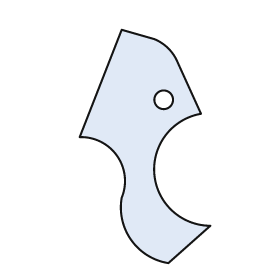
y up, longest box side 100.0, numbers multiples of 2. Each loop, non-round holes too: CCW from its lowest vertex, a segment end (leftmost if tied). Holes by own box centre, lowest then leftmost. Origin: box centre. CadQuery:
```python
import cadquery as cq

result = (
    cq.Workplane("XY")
    .moveTo(10.0, -50.0)
    .lineTo(28.0, -34.0)
    .threePointArc((4.0, -12.0), (24.0, 14.0))
    .lineTo(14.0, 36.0)
    .threePointArc((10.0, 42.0), (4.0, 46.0))
    .lineTo(-10.0, 50.0)
    .lineTo(-28.0, 4.0)
    .threePointArc((-12.0, -4.0), (-10.0, -22.0))
    .threePointArc((-6.0, -40.0), (10.0, -50.0))
    .close()
    .moveTo(8.0, 20.0)
    .circle(4.0)
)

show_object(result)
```